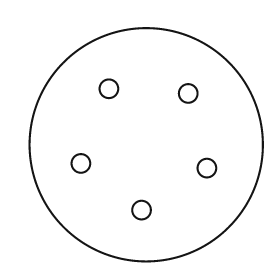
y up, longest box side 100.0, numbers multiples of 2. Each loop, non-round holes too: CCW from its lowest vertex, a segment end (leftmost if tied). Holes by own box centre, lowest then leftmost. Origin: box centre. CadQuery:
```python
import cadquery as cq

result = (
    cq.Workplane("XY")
    .moveTo(0.0, 0.0)
    .circle(50.0)
    .moveTo(-2.0, -28.0)
    .circle(4.0)
    .moveTo(26.0, -10.0)
    .circle(4.0)
    .moveTo(-28.0, -8.0)
    .circle(4.0)
    .moveTo(18.0, 22.0)
    .circle(4.0)
    .moveTo(-16.0, 24.0)
    .circle(4.0)
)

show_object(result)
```